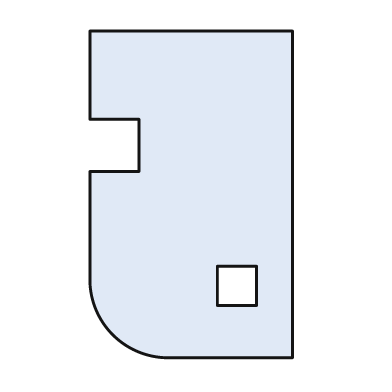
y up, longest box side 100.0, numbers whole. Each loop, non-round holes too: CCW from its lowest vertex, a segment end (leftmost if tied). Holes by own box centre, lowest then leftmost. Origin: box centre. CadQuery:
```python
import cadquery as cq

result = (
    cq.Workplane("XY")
    .moveTo(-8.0, -50.0)
    .lineTo(31.0, -50.0)
    .lineTo(31.0, 50.0)
    .lineTo(-31.0, 50.0)
    .lineTo(-31.0, 23.0)
    .lineTo(-16.0, 23.0)
    .lineTo(-16.0, 7.0)
    .lineTo(-31.0, 7.0)
    .lineTo(-31.0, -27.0)
    .threePointArc((-24.0, -43.0), (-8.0, -50.0))
    .close()
    .moveTo(8.0, -34.0)
    .lineTo(20.0, -34.0)
    .lineTo(20.0, -22.0)
    .lineTo(8.0, -22.0)
    .close()
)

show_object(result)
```